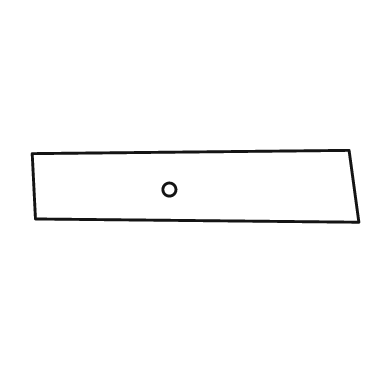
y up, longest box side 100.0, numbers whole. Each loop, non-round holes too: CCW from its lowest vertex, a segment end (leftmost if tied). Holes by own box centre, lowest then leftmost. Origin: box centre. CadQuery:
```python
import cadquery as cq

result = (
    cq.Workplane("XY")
    .moveTo(50.0, -11.0)
    .lineTo(47.0, 11.0)
    .lineTo(-50.0, 10.0)
    .lineTo(-49.0, -10.0)
    .close()
    .moveTo(-8.0, -1.0)
    .circle(2.0)
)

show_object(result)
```